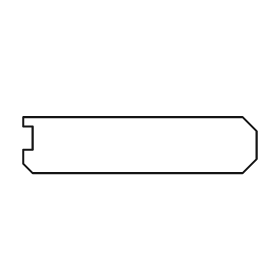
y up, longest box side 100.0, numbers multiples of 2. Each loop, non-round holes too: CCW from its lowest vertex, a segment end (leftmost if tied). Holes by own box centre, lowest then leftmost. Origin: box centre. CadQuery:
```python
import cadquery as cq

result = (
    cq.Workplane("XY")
    .moveTo(-46.0, -12.0)
    .lineTo(44.0, -12.0)
    .lineTo(50.0, -6.0)
    .lineTo(50.0, 6.0)
    .lineTo(44.0, 12.0)
    .lineTo(-50.0, 12.0)
    .lineTo(-50.0, 8.0)
    .lineTo(-46.0, 8.0)
    .lineTo(-46.0, -2.0)
    .lineTo(-50.0, -2.0)
    .lineTo(-50.0, -8.0)
    .close()
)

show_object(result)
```